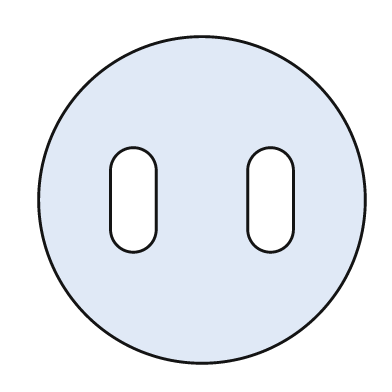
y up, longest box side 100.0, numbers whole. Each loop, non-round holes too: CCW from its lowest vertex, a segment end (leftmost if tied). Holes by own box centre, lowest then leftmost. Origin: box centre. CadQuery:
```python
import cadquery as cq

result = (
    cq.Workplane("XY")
    .moveTo(0.0, 0.0)
    .circle(50.0)
    .moveTo(-28.0, -9.0)
    .threePointArc((-21.0, -16.0), (-14.0, -9.0))
    .lineTo(-14.0, 9.0)
    .threePointArc((-21.0, 16.0), (-28.0, 9.0))
    .close()
    .moveTo(14.0, -9.0)
    .threePointArc((21.0, -16.0), (28.0, -9.0))
    .lineTo(28.0, 9.0)
    .threePointArc((21.0, 16.0), (14.0, 9.0))
    .close()
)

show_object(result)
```